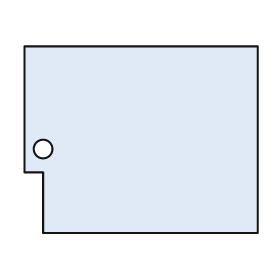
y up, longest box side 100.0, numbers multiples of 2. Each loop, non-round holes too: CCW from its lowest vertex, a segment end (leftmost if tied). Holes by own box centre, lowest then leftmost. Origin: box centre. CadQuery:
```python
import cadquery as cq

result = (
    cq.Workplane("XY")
    .moveTo(-42.0, -40.0)
    .lineTo(50.0, -40.0)
    .lineTo(50.0, 40.0)
    .lineTo(-50.0, 40.0)
    .lineTo(-50.0, -14.0)
    .lineTo(-42.0, -14.0)
    .close()
    .moveTo(-42.0, -4.0)
    .circle(4.0)
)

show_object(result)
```